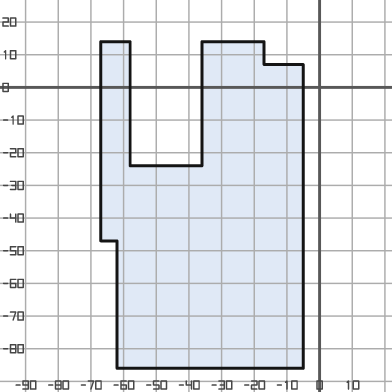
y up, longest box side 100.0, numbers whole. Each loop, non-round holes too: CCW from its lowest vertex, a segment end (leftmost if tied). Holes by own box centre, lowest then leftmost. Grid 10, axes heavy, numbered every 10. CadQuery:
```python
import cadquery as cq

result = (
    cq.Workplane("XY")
    .moveTo(-62.0, -86.0)
    .lineTo(-5.0, -86.0)
    .lineTo(-5.0, 7.0)
    .lineTo(-17.0, 7.0)
    .lineTo(-17.0, 14.0)
    .lineTo(-36.0, 14.0)
    .lineTo(-36.0, -24.0)
    .lineTo(-58.0, -24.0)
    .lineTo(-58.0, 14.0)
    .lineTo(-67.0, 14.0)
    .lineTo(-67.0, -47.0)
    .lineTo(-62.0, -47.0)
    .close()
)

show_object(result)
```